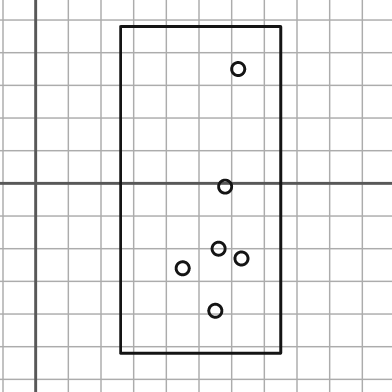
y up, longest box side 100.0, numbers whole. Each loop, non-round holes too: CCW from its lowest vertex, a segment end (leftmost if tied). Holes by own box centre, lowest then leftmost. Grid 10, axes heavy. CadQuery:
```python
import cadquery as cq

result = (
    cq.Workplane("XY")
    .moveTo(26.0, -52.0)
    .lineTo(75.0, -52.0)
    .lineTo(75.0, 48.0)
    .lineTo(26.0, 48.0)
    .close()
    .moveTo(55.0, -39.0)
    .circle(2.0)
    .moveTo(45.0, -26.0)
    .circle(2.0)
    .moveTo(63.0, -23.0)
    .circle(2.0)
    .moveTo(56.0, -20.0)
    .circle(2.0)
    .moveTo(58.0, -1.0)
    .circle(2.0)
    .moveTo(62.0, 35.0)
    .circle(2.0)
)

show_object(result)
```